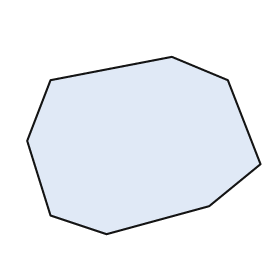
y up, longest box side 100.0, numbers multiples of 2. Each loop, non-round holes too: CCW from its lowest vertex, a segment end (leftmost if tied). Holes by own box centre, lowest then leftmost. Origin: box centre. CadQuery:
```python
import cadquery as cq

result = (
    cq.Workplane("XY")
    .moveTo(-16.0, -38.0)
    .lineTo(28.0, -26.0)
    .lineTo(50.0, -8.0)
    .lineTo(36.0, 28.0)
    .lineTo(12.0, 38.0)
    .lineTo(-40.0, 28.0)
    .lineTo(-50.0, 2.0)
    .lineTo(-40.0, -30.0)
    .close()
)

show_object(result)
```